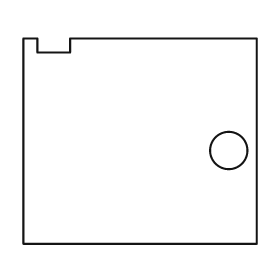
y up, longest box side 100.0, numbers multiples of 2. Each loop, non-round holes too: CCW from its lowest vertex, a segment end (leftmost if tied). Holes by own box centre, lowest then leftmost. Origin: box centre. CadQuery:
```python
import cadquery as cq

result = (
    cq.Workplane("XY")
    .moveTo(-50.0, -44.0)
    .lineTo(50.0, -44.0)
    .lineTo(50.0, 44.0)
    .lineTo(-30.0, 44.0)
    .lineTo(-30.0, 38.0)
    .lineTo(-44.0, 38.0)
    .lineTo(-44.0, 44.0)
    .lineTo(-50.0, 44.0)
    .close()
    .moveTo(38.0, -4.0)
    .circle(8.0)
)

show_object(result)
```